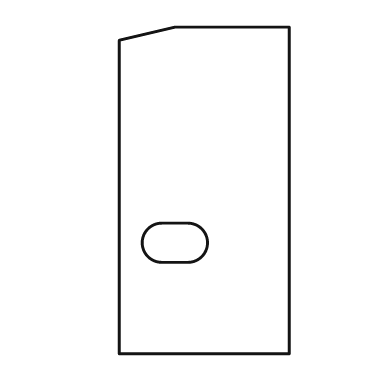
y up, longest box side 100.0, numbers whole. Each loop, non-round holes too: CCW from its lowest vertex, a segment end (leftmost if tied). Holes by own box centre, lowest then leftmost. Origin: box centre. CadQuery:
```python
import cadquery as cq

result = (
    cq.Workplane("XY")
    .moveTo(-26.0, -50.0)
    .lineTo(26.0, -50.0)
    .lineTo(26.0, 50.0)
    .lineTo(-9.0, 50.0)
    .lineTo(-26.0, 46.0)
    .close()
    .moveTo(-13.0, -22.0)
    .lineTo(-5.0, -22.0)
    .threePointArc((1.0, -16.0), (-5.0, -10.0))
    .lineTo(-13.0, -10.0)
    .threePointArc((-19.0, -16.0), (-13.0, -22.0))
    .close()
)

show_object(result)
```